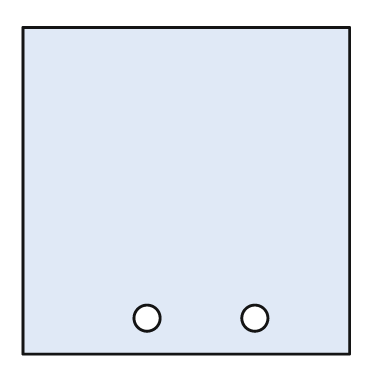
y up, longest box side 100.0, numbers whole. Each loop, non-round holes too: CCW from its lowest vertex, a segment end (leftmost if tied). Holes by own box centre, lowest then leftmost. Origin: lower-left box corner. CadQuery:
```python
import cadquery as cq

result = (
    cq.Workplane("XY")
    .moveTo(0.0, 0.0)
    .lineTo(100.0, 0.0)
    .lineTo(100.0, 100.0)
    .lineTo(0.0, 100.0)
    .close()
    .moveTo(38.0, 11.0)
    .circle(4.0)
    .moveTo(71.0, 11.0)
    .circle(4.0)
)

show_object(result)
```